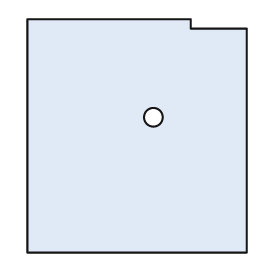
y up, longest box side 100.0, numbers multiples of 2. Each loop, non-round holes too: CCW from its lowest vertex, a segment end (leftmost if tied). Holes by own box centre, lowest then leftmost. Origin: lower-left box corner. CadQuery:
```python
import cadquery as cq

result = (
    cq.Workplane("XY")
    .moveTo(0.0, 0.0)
    .lineTo(94.0, 0.0)
    .lineTo(94.0, 96.0)
    .lineTo(70.0, 96.0)
    .lineTo(70.0, 100.0)
    .lineTo(0.0, 100.0)
    .close()
    .moveTo(54.0, 58.0)
    .circle(4.0)
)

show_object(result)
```